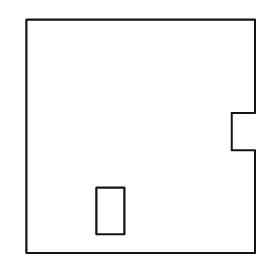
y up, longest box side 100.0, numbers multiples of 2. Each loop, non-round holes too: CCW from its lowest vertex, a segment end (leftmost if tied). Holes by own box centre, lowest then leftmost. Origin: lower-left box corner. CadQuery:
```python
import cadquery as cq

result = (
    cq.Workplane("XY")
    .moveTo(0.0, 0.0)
    .lineTo(98.0, 0.0)
    .lineTo(98.0, 44.0)
    .lineTo(88.0, 44.0)
    .lineTo(88.0, 60.0)
    .lineTo(98.0, 60.0)
    .lineTo(98.0, 100.0)
    .lineTo(0.0, 100.0)
    .close()
    .moveTo(30.0, 8.0)
    .lineTo(42.0, 8.0)
    .lineTo(42.0, 28.0)
    .lineTo(30.0, 28.0)
    .close()
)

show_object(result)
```